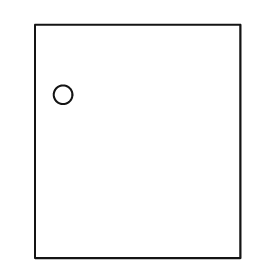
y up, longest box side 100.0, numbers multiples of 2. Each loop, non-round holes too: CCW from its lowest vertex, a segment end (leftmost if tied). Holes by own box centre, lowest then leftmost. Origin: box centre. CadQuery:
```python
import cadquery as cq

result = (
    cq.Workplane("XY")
    .moveTo(-44.0, -50.0)
    .lineTo(44.0, -50.0)
    .lineTo(44.0, 50.0)
    .lineTo(-44.0, 50.0)
    .close()
    .moveTo(-32.0, 20.0)
    .circle(4.0)
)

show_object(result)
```